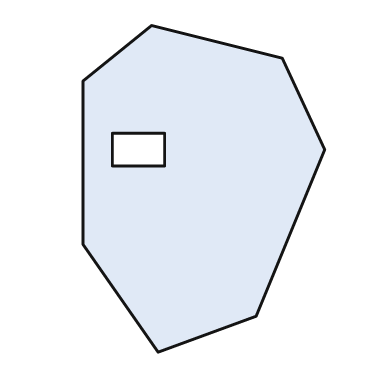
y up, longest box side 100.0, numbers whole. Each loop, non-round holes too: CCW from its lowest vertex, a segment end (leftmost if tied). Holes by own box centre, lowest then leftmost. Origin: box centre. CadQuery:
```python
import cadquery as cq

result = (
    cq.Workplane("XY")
    .moveTo(-14.0, -50.0)
    .lineTo(16.0, -39.0)
    .lineTo(37.0, 12.0)
    .lineTo(24.0, 40.0)
    .lineTo(-16.0, 50.0)
    .lineTo(-37.0, 33.0)
    .lineTo(-37.0, -17.0)
    .close()
    .moveTo(-28.0, 7.0)
    .lineTo(-12.0, 7.0)
    .lineTo(-12.0, 17.0)
    .lineTo(-28.0, 17.0)
    .close()
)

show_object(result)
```